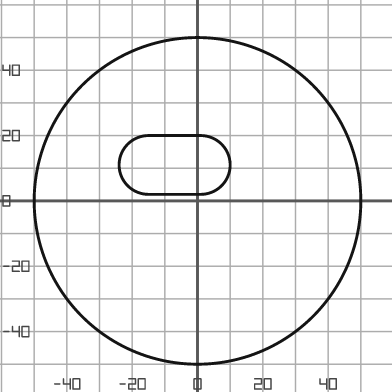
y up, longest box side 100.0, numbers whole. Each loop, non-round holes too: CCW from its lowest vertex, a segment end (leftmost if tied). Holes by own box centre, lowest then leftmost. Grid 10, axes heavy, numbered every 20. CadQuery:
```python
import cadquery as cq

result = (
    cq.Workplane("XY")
    .moveTo(0.0, 0.0)
    .circle(50.0)
    .moveTo(-15.0, 2.0)
    .lineTo(1.0, 2.0)
    .threePointArc((10.0, 11.0), (1.0, 20.0))
    .lineTo(-15.0, 20.0)
    .threePointArc((-24.0, 11.0), (-15.0, 2.0))
    .close()
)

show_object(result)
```